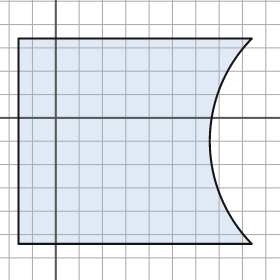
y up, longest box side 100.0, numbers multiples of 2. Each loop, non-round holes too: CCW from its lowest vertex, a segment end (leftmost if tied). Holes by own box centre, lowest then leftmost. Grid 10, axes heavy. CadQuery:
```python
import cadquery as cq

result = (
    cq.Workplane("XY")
    .moveTo(-16.0, -54.0)
    .lineTo(84.0, -54.0)
    .threePointArc((66.0, -10.0), (84.0, 34.0))
    .lineTo(-16.0, 34.0)
    .close()
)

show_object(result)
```